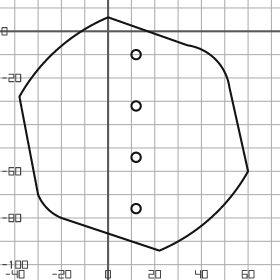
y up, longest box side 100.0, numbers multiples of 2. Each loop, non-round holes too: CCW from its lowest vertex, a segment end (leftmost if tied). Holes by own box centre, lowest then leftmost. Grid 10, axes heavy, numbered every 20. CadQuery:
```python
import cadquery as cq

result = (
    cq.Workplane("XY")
    .moveTo(22.0, -94.0)
    .threePointArc((44.0, -80.0), (60.0, -60.0))
    .lineTo(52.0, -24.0)
    .threePointArc((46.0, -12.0), (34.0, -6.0))
    .lineTo(0.0, 6.0)
    .threePointArc((-22.0, -8.0), (-38.0, -28.0))
    .lineTo(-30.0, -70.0)
    .threePointArc((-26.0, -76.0), (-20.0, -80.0))
    .close()
    .moveTo(12.0, -76.0)
    .circle(2.0)
    .moveTo(12.0, -54.0)
    .circle(2.0)
    .moveTo(12.0, -32.0)
    .circle(2.0)
    .moveTo(12.0, -10.0)
    .circle(2.0)
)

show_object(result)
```